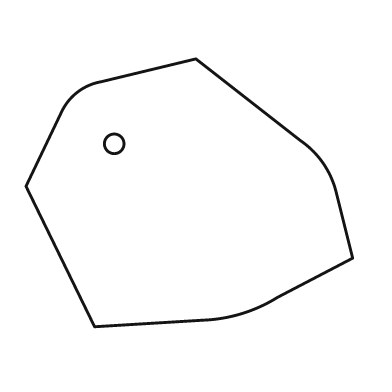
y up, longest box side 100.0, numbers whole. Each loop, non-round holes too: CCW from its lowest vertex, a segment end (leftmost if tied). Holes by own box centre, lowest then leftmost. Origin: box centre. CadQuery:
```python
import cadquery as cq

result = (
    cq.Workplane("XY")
    .moveTo(-29.0, -41.0)
    .lineTo(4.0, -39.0)
    .threePointArc((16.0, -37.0), (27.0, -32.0))
    .lineTo(50.0, -20.0)
    .lineTo(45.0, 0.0)
    .threePointArc((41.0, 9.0), (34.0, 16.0))
    .lineTo(2.0, 41.0)
    .lineTo(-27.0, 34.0)
    .threePointArc((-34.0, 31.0), (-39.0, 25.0))
    .lineTo(-50.0, 2.0)
    .close()
    .moveTo(-23.0, 15.0)
    .circle(3.0)
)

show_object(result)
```